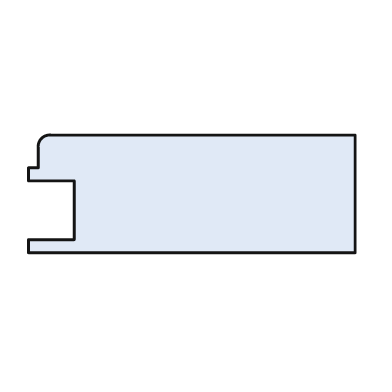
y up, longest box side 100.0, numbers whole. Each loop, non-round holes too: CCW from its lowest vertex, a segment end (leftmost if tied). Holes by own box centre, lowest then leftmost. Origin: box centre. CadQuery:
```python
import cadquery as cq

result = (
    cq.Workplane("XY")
    .moveTo(-50.0, -18.0)
    .lineTo(50.0, -18.0)
    .lineTo(50.0, 18.0)
    .lineTo(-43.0, 18.0)
    .threePointArc((-46.0, 17.0), (-47.0, 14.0))
    .lineTo(-47.0, 8.0)
    .lineTo(-50.0, 8.0)
    .lineTo(-50.0, 4.0)
    .lineTo(-36.0, 4.0)
    .lineTo(-36.0, -14.0)
    .lineTo(-50.0, -14.0)
    .close()
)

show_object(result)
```